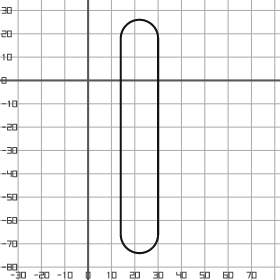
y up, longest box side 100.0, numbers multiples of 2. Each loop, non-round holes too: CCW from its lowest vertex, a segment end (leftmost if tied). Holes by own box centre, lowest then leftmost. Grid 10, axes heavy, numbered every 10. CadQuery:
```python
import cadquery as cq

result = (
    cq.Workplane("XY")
    .moveTo(14.0, -66.0)
    .threePointArc((22.0, -74.0), (30.0, -66.0))
    .lineTo(30.0, 18.0)
    .threePointArc((22.0, 26.0), (14.0, 18.0))
    .close()
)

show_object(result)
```